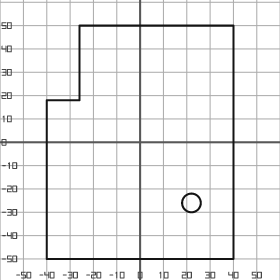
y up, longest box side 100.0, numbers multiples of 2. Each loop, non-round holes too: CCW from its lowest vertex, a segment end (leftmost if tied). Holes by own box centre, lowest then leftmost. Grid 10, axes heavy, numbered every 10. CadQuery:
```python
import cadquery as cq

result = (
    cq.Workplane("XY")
    .moveTo(-40.0, -50.0)
    .lineTo(40.0, -50.0)
    .lineTo(40.0, 50.0)
    .lineTo(-26.0, 50.0)
    .lineTo(-26.0, 18.0)
    .lineTo(-40.0, 18.0)
    .close()
    .moveTo(22.0, -26.0)
    .circle(4.0)
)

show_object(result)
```